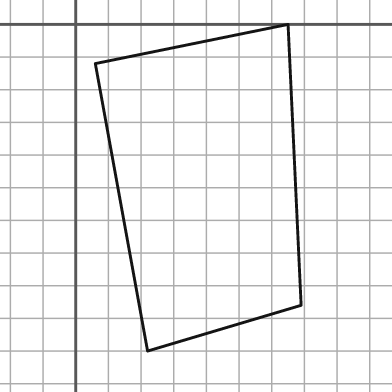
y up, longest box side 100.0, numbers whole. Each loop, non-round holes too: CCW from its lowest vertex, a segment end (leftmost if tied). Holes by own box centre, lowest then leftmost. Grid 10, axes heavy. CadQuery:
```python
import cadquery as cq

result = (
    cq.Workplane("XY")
    .moveTo(22.0, -100.0)
    .lineTo(69.0, -86.0)
    .lineTo(65.0, 0.0)
    .lineTo(6.0, -12.0)
    .close()
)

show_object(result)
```